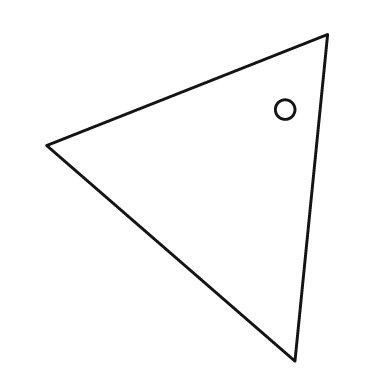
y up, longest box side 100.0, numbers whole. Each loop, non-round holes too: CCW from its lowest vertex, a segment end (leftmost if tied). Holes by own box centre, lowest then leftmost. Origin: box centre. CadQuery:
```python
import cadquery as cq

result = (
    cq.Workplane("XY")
    .moveTo(33.0, -50.0)
    .lineTo(43.0, 50.0)
    .lineTo(-43.0, 16.0)
    .close()
    .moveTo(30.0, 27.0)
    .circle(3.0)
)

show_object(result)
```